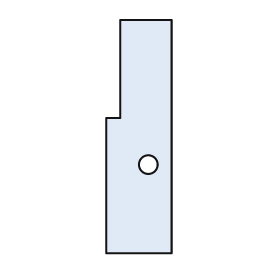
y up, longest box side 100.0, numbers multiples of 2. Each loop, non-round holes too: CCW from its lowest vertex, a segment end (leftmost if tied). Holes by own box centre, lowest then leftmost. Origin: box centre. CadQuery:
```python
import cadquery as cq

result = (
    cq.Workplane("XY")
    .moveTo(-14.0, -50.0)
    .lineTo(14.0, -50.0)
    .lineTo(14.0, 50.0)
    .lineTo(-8.0, 50.0)
    .lineTo(-8.0, 8.0)
    .lineTo(-14.0, 8.0)
    .close()
    .moveTo(4.0, -12.0)
    .circle(4.0)
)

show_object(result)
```